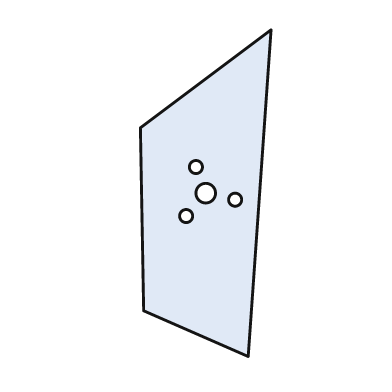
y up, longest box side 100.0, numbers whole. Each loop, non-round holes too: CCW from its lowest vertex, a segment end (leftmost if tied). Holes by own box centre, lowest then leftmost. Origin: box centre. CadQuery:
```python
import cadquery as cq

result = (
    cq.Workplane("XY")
    .moveTo(13.0, -50.0)
    .lineTo(20.0, 50.0)
    .lineTo(-20.0, 20.0)
    .lineTo(-19.0, -36.0)
    .close()
    .moveTo(-6.0, -7.0)
    .circle(2.0)
    .moveTo(9.0, -2.0)
    .circle(2.0)
    .moveTo(0.0, 0.0)
    .circle(3.0)
    .moveTo(-3.0, 8.0)
    .circle(2.0)
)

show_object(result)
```